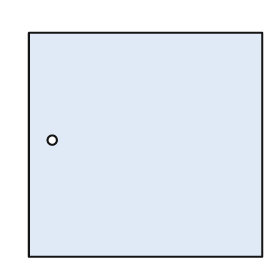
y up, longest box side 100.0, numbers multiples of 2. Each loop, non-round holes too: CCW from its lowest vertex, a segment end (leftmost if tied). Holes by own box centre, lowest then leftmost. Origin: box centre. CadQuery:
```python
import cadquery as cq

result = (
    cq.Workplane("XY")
    .moveTo(-50.0, -48.0)
    .lineTo(50.0, -48.0)
    .lineTo(50.0, 48.0)
    .lineTo(-50.0, 48.0)
    .close()
    .moveTo(-40.0, 2.0)
    .circle(2.0)
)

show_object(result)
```